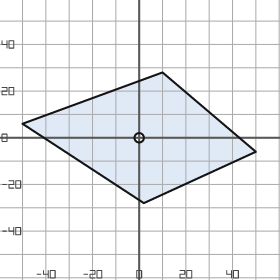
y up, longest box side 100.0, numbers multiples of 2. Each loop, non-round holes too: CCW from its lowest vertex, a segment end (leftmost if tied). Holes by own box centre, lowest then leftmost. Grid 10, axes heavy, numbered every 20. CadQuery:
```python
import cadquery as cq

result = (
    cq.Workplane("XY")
    .moveTo(2.0, -28.0)
    .lineTo(50.0, -6.0)
    .lineTo(10.0, 28.0)
    .lineTo(-50.0, 6.0)
    .close()
    .moveTo(0.0, 0.0)
    .circle(2.0)
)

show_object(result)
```